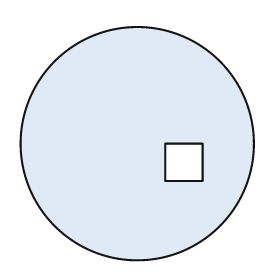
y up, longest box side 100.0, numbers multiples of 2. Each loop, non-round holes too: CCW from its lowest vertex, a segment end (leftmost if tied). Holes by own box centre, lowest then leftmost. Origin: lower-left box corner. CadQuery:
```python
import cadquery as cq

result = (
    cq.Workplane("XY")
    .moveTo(50.0, 50.0)
    .circle(50.0)
    .moveTo(62.0, 34.0)
    .lineTo(78.0, 34.0)
    .lineTo(78.0, 50.0)
    .lineTo(62.0, 50.0)
    .close()
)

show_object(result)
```